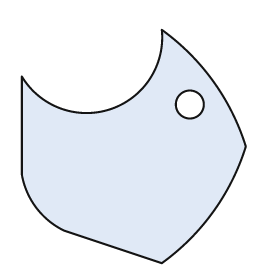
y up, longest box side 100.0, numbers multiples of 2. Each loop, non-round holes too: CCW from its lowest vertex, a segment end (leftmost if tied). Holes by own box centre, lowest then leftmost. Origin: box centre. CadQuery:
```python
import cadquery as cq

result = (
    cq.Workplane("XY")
    .moveTo(12.0, -50.0)
    .threePointArc((34.0, -28.0), (48.0, 0.0))
    .threePointArc((34.0, 28.0), (12.0, 50.0))
    .threePointArc((-10.0, 16.0), (-48.0, 30.0))
    .lineTo(-48.0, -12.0)
    .threePointArc((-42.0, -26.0), (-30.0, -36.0))
    .close()
    .moveTo(24.0, 18.0)
    .circle(6.0)
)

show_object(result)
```